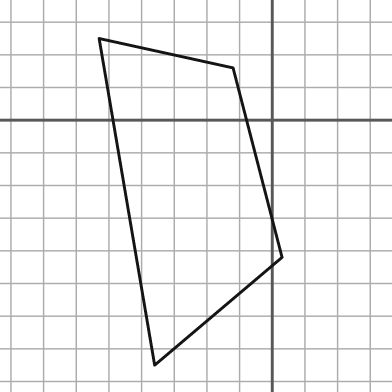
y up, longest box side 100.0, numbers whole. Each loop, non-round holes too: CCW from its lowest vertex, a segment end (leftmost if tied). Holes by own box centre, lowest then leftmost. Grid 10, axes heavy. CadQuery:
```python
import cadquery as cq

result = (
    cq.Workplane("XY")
    .moveTo(-36.0, -75.0)
    .lineTo(3.0, -42.0)
    .lineTo(-12.0, 16.0)
    .lineTo(-53.0, 25.0)
    .close()
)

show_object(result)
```